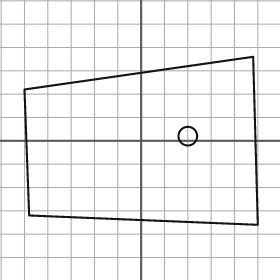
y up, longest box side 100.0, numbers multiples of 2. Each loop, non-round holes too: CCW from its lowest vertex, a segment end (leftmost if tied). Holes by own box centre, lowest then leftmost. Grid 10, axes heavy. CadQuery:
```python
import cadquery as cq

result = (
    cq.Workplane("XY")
    .moveTo(50.0, -36.0)
    .lineTo(48.0, 36.0)
    .lineTo(-50.0, 22.0)
    .lineTo(-48.0, -32.0)
    .close()
    .moveTo(20.0, 2.0)
    .circle(4.0)
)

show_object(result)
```